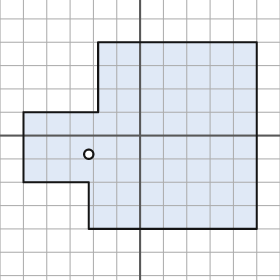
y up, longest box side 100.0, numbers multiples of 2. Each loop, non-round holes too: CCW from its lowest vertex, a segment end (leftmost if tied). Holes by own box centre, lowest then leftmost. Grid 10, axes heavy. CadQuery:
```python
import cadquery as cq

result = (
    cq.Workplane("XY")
    .moveTo(-22.0, -40.0)
    .lineTo(50.0, -40.0)
    .lineTo(50.0, 40.0)
    .lineTo(-18.0, 40.0)
    .lineTo(-18.0, 10.0)
    .lineTo(-50.0, 10.0)
    .lineTo(-50.0, -20.0)
    .lineTo(-22.0, -20.0)
    .close()
    .moveTo(-22.0, -8.0)
    .circle(2.0)
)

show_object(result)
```